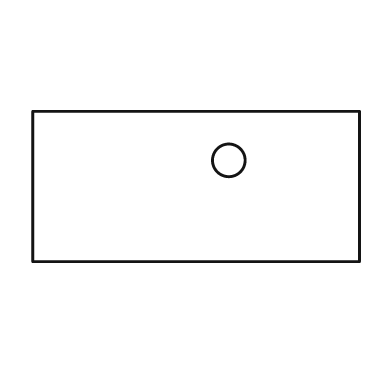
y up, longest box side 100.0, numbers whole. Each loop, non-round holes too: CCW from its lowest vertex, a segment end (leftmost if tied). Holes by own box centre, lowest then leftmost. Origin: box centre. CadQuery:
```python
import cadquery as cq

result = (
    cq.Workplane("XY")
    .moveTo(-50.0, -23.0)
    .lineTo(50.0, -23.0)
    .lineTo(50.0, 23.0)
    .lineTo(-50.0, 23.0)
    .close()
    .moveTo(10.0, 8.0)
    .circle(5.0)
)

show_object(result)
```